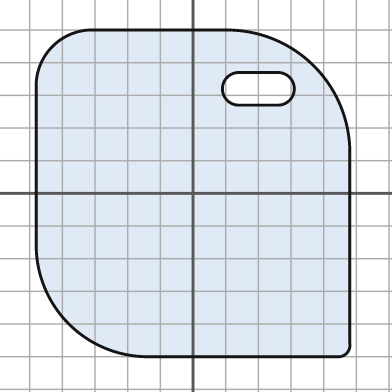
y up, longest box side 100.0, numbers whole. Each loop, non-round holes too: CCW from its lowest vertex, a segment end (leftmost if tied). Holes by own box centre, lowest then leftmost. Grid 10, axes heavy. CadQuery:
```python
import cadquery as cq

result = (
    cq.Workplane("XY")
    .moveTo(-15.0, -50.0)
    .lineTo(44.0, -50.0)
    .threePointArc((47.0, -49.0), (48.0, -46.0))
    .lineTo(48.0, 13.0)
    .threePointArc((37.0, 39.0), (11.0, 50.0))
    .lineTo(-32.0, 50.0)
    .threePointArc((-43.0, 45.0), (-48.0, 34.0))
    .lineTo(-48.0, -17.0)
    .threePointArc((-38.0, -40.0), (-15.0, -50.0))
    .close()
    .moveTo(14.0, 27.0)
    .lineTo(26.0, 27.0)
    .threePointArc((31.0, 32.0), (26.0, 37.0))
    .lineTo(14.0, 37.0)
    .threePointArc((9.0, 32.0), (14.0, 27.0))
    .close()
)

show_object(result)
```